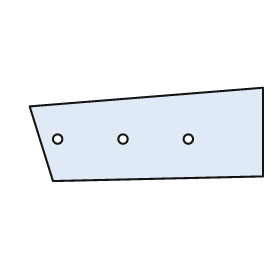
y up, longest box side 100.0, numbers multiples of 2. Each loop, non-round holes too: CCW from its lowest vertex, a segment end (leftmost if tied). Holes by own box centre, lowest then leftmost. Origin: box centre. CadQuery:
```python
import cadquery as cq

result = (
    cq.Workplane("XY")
    .moveTo(-40.0, -20.0)
    .lineTo(50.0, -18.0)
    .lineTo(50.0, 20.0)
    .lineTo(-50.0, 12.0)
    .close()
    .moveTo(-38.0, -2.0)
    .circle(2.0)
    .moveTo(-10.0, -2.0)
    .circle(2.0)
    .moveTo(18.0, -2.0)
    .circle(2.0)
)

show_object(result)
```